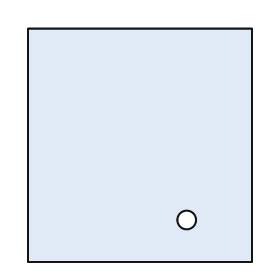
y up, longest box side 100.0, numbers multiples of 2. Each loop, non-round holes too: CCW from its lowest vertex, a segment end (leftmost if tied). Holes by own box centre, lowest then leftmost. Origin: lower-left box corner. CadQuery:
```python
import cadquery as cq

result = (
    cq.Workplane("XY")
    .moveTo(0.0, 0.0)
    .lineTo(96.0, 0.0)
    .lineTo(96.0, 100.0)
    .lineTo(0.0, 100.0)
    .close()
    .moveTo(68.0, 18.0)
    .circle(4.0)
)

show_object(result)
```